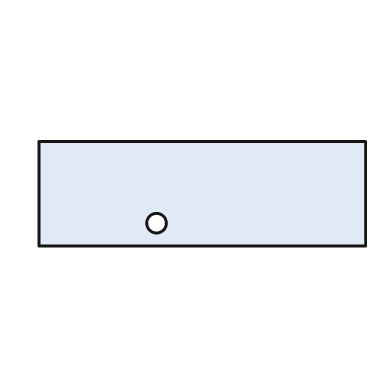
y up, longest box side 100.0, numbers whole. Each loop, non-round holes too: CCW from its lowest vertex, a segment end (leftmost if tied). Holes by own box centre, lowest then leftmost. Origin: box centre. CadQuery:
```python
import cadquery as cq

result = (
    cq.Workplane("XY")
    .moveTo(-50.0, -16.0)
    .lineTo(50.0, -16.0)
    .lineTo(50.0, 16.0)
    .lineTo(-50.0, 16.0)
    .close()
    .moveTo(-14.0, -9.0)
    .circle(3.0)
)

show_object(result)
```